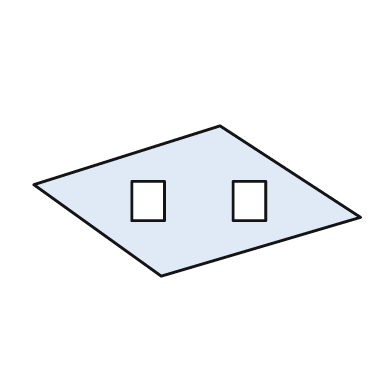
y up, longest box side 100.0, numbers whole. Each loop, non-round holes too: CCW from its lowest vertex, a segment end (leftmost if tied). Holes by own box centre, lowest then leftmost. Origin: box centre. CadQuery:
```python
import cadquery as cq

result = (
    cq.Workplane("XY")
    .moveTo(-11.0, -23.0)
    .lineTo(50.0, -5.0)
    .lineTo(7.0, 23.0)
    .lineTo(-50.0, 5.0)
    .close()
    .moveTo(-20.0, -6.0)
    .lineTo(-10.0, -6.0)
    .lineTo(-10.0, 6.0)
    .lineTo(-20.0, 6.0)
    .close()
    .moveTo(11.0, -6.0)
    .lineTo(21.0, -6.0)
    .lineTo(21.0, 6.0)
    .lineTo(11.0, 6.0)
    .close()
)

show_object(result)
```